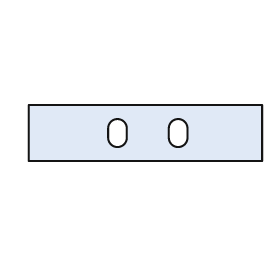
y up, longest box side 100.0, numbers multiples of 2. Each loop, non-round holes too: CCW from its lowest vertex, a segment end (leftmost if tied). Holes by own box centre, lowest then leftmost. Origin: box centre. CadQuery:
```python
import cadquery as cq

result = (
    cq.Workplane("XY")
    .moveTo(-50.0, -12.0)
    .lineTo(50.0, -12.0)
    .lineTo(50.0, 12.0)
    .lineTo(-50.0, 12.0)
    .close()
    .moveTo(-16.0, -2.0)
    .threePointArc((-12.0, -6.0), (-8.0, -2.0))
    .lineTo(-8.0, 2.0)
    .threePointArc((-12.0, 6.0), (-16.0, 2.0))
    .close()
    .moveTo(10.0, -2.0)
    .threePointArc((14.0, -6.0), (18.0, -2.0))
    .lineTo(18.0, 2.0)
    .threePointArc((14.0, 6.0), (10.0, 2.0))
    .close()
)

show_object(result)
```